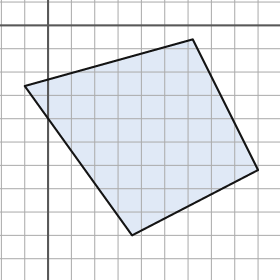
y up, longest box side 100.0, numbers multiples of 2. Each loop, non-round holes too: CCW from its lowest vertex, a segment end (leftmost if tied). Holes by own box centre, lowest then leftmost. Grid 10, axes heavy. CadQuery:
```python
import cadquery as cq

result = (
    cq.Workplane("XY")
    .moveTo(36.0, -90.0)
    .lineTo(90.0, -62.0)
    .lineTo(62.0, -6.0)
    .lineTo(-10.0, -26.0)
    .close()
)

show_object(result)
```